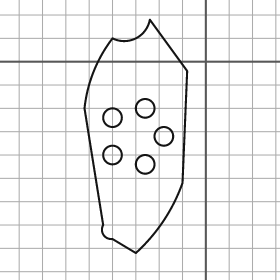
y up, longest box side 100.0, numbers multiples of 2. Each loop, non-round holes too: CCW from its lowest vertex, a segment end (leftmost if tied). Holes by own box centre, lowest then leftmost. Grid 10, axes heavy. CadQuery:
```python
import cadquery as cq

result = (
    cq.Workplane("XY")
    .moveTo(-30.0, -82.0)
    .threePointArc((-18.0, -68.0), (-10.0, -52.0))
    .lineTo(-8.0, -4.0)
    .lineTo(-24.0, 18.0)
    .threePointArc((-30.0, 10.0), (-40.0, 10.0))
    .threePointArc((-48.0, -4.0), (-52.0, -20.0))
    .lineTo(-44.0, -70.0)
    .threePointArc((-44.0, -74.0), (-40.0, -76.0))
    .close()
    .moveTo(-26.0, -44.0)
    .circle(4.0)
    .moveTo(-40.0, -40.0)
    .circle(4.0)
    .moveTo(-18.0, -32.0)
    .circle(4.0)
    .moveTo(-40.0, -24.0)
    .circle(4.0)
    .moveTo(-26.0, -20.0)
    .circle(4.0)
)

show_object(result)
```